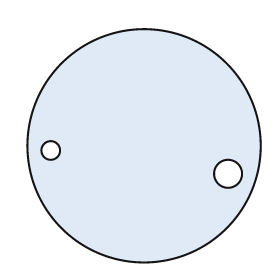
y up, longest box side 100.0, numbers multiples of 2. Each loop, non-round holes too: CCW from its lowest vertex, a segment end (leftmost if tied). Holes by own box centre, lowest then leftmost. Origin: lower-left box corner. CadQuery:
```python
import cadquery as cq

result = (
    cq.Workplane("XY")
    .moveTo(50.0, 50.0)
    .circle(50.0)
    .moveTo(86.0, 38.0)
    .circle(6.0)
    .moveTo(10.0, 48.0)
    .circle(4.0)
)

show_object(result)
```